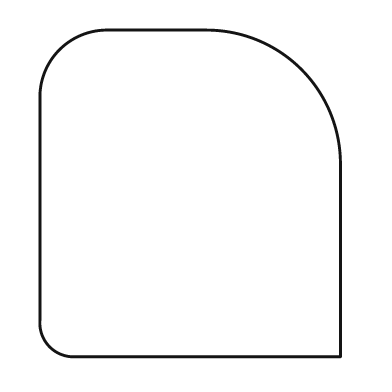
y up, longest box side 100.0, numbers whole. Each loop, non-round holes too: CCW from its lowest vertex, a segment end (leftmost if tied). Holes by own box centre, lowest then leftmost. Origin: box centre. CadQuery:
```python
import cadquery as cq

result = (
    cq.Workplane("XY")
    .moveTo(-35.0, -50.0)
    .lineTo(46.0, -50.0)
    .lineTo(46.0, 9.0)
    .threePointArc((34.0, 38.0), (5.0, 50.0))
    .lineTo(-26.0, 50.0)
    .threePointArc((-40.0, 44.0), (-46.0, 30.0))
    .lineTo(-46.0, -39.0)
    .threePointArc((-43.0, -47.0), (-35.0, -50.0))
    .close()
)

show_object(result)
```